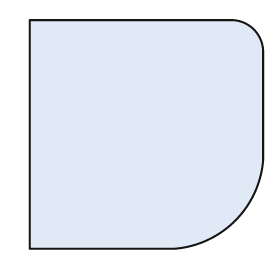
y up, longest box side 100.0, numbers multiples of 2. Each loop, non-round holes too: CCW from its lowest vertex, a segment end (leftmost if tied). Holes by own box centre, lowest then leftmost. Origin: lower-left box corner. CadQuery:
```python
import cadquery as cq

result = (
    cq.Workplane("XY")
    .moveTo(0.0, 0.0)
    .lineTo(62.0, 0.0)
    .threePointArc((88.0, 12.0), (100.0, 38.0))
    .lineTo(100.0, 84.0)
    .threePointArc((96.0, 94.0), (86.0, 98.0))
    .lineTo(0.0, 98.0)
    .close()
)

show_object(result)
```